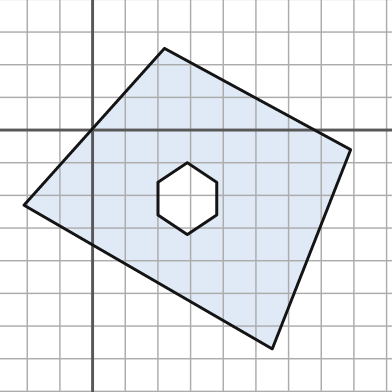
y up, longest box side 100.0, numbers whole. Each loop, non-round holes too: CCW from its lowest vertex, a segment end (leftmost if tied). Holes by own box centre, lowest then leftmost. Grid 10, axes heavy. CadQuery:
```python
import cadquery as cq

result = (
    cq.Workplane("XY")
    .moveTo(55.0, -67.0)
    .lineTo(79.0, -6.0)
    .lineTo(22.0, 25.0)
    .lineTo(-21.0, -23.0)
    .close()
    .moveTo(29.0, -32.0)
    .lineTo(38.0, -26.0)
    .lineTo(38.0, -16.0)
    .lineTo(29.0, -10.0)
    .lineTo(20.0, -16.0)
    .lineTo(20.0, -26.0)
    .close()
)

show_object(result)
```